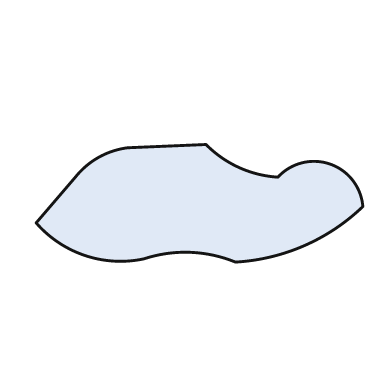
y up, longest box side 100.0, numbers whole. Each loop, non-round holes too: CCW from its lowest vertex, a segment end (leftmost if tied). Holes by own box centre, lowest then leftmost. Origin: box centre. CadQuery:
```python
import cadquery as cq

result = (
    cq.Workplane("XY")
    .moveTo(11.0, -18.0)
    .threePointArc((32.0, -13.0), (50.0, -1.0))
    .threePointArc((40.0, 12.0), (24.0, 8.0))
    .threePointArc((12.0, 11.0), (2.0, 18.0))
    .lineTo(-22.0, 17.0)
    .threePointArc((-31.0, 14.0), (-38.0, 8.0))
    .lineTo(-50.0, -6.0)
    .threePointArc((-35.0, -16.0), (-17.0, -17.0))
    .threePointArc((-3.0, -15.0), (11.0, -18.0))
    .close()
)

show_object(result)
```